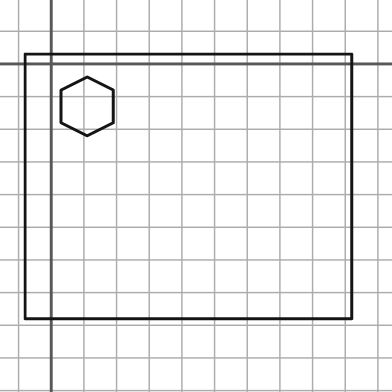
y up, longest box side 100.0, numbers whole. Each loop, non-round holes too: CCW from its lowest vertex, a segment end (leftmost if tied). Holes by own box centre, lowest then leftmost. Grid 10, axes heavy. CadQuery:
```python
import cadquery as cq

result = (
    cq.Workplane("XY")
    .moveTo(-8.0, -78.0)
    .lineTo(92.0, -78.0)
    .lineTo(92.0, 3.0)
    .lineTo(-8.0, 3.0)
    .close()
    .moveTo(11.0, -22.0)
    .lineTo(19.0, -18.0)
    .lineTo(19.0, -8.0)
    .lineTo(11.0, -4.0)
    .lineTo(3.0, -8.0)
    .lineTo(3.0, -18.0)
    .close()
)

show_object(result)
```